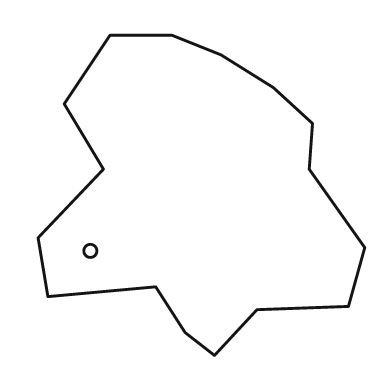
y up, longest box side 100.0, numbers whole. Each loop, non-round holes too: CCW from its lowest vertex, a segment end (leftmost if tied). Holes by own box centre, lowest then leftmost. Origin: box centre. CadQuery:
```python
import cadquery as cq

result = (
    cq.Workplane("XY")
    .moveTo(4.0, -49.0)
    .lineTo(17.0, -35.0)
    .lineTo(45.0, -34.0)
    .lineTo(50.0, -16.0)
    .lineTo(33.0, 8.0)
    .lineTo(34.0, 22.0)
    .lineTo(22.0, 33.0)
    .lineTo(6.0, 43.0)
    .lineTo(-9.0, 49.0)
    .lineTo(-28.0, 49.0)
    .lineTo(-42.0, 28.0)
    .lineTo(-30.0, 8.0)
    .lineTo(-50.0, -13.0)
    .lineTo(-47.0, -31.0)
    .lineTo(-14.0, -28.0)
    .lineTo(-5.0, -42.0)
    .close()
    .moveTo(-34.0, -17.0)
    .circle(2.0)
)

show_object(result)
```